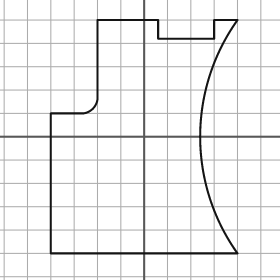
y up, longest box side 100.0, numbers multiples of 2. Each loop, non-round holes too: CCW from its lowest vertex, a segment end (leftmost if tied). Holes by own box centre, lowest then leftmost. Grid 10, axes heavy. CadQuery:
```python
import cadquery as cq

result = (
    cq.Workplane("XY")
    .moveTo(-40.0, -50.0)
    .lineTo(40.0, -50.0)
    .threePointArc((24.0, 0.0), (40.0, 50.0))
    .lineTo(30.0, 50.0)
    .lineTo(30.0, 42.0)
    .lineTo(6.0, 42.0)
    .lineTo(6.0, 50.0)
    .lineTo(-20.0, 50.0)
    .lineTo(-20.0, 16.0)
    .threePointArc((-22.0, 12.0), (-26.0, 10.0))
    .lineTo(-40.0, 10.0)
    .close()
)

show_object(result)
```